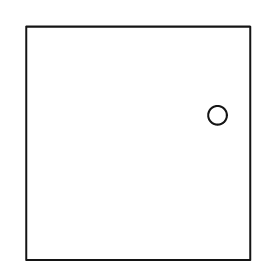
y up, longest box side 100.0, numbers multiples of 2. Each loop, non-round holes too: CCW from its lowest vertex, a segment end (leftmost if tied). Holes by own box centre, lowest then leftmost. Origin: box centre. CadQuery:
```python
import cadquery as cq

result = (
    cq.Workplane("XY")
    .moveTo(-48.0, -50.0)
    .lineTo(48.0, -50.0)
    .lineTo(48.0, 50.0)
    .lineTo(-48.0, 50.0)
    .close()
    .moveTo(34.0, 12.0)
    .circle(4.0)
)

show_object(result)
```